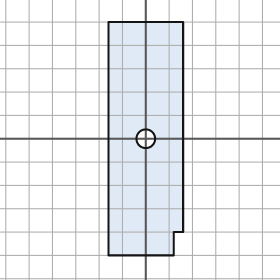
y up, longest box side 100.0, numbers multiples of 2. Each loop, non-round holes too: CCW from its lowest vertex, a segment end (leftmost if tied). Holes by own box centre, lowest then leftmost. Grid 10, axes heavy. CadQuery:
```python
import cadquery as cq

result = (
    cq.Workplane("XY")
    .moveTo(-16.0, -50.0)
    .lineTo(12.0, -50.0)
    .lineTo(12.0, -40.0)
    .lineTo(16.0, -40.0)
    .lineTo(16.0, 50.0)
    .lineTo(-16.0, 50.0)
    .close()
    .moveTo(0.0, 0.0)
    .circle(4.0)
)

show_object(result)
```